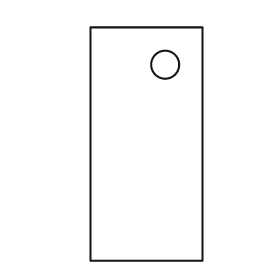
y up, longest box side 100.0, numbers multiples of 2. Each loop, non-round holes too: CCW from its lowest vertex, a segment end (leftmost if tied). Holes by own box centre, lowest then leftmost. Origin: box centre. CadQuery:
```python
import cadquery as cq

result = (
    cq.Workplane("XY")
    .moveTo(-24.0, -50.0)
    .lineTo(24.0, -50.0)
    .lineTo(24.0, 50.0)
    .lineTo(-24.0, 50.0)
    .close()
    .moveTo(8.0, 34.0)
    .circle(6.0)
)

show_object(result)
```